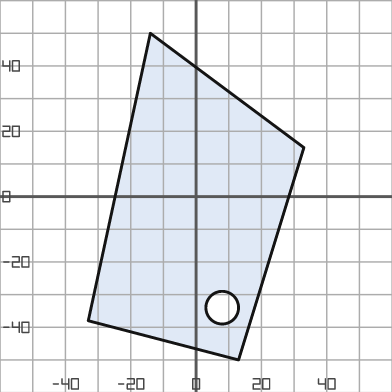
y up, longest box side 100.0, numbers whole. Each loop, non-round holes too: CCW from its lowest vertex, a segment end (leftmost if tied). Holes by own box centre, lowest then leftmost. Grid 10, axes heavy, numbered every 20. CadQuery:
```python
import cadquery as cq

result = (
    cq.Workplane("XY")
    .moveTo(13.0, -50.0)
    .lineTo(33.0, 15.0)
    .lineTo(-14.0, 50.0)
    .lineTo(-33.0, -38.0)
    .close()
    .moveTo(8.0, -34.0)
    .circle(5.0)
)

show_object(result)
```